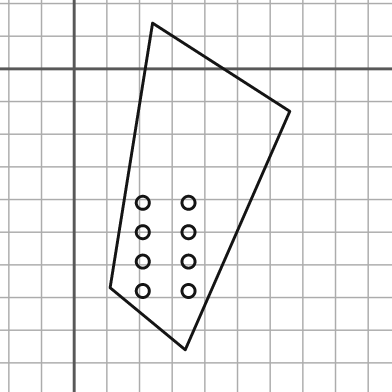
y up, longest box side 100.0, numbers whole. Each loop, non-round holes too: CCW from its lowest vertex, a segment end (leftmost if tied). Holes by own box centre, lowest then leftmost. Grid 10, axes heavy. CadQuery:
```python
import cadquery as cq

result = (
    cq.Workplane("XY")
    .moveTo(34.0, -86.0)
    .lineTo(66.0, -13.0)
    .lineTo(24.0, 14.0)
    .lineTo(11.0, -67.0)
    .close()
    .moveTo(21.0, -68.0)
    .circle(2.0)
    .moveTo(35.0, -68.0)
    .circle(2.0)
    .moveTo(21.0, -59.0)
    .circle(2.0)
    .moveTo(35.0, -59.0)
    .circle(2.0)
    .moveTo(21.0, -50.0)
    .circle(2.0)
    .moveTo(35.0, -50.0)
    .circle(2.0)
    .moveTo(21.0, -41.0)
    .circle(2.0)
    .moveTo(35.0, -41.0)
    .circle(2.0)
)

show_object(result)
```